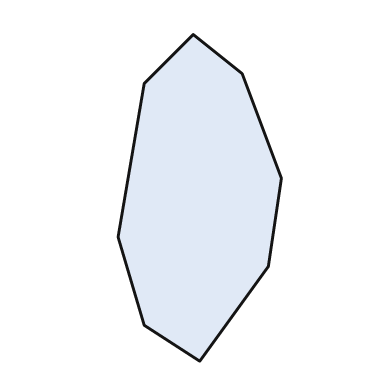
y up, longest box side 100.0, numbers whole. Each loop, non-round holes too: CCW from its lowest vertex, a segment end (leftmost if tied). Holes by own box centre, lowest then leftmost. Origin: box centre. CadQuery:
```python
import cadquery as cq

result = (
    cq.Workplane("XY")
    .moveTo(0.0, -50.0)
    .lineTo(21.0, -21.0)
    .lineTo(25.0, 6.0)
    .lineTo(13.0, 38.0)
    .lineTo(-2.0, 50.0)
    .lineTo(-17.0, 35.0)
    .lineTo(-25.0, -12.0)
    .lineTo(-17.0, -39.0)
    .close()
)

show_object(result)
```